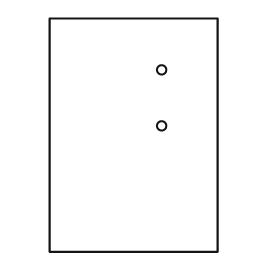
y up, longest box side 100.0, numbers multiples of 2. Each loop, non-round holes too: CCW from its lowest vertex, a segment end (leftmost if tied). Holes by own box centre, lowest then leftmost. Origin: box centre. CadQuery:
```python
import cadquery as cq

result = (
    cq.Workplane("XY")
    .moveTo(-36.0, -50.0)
    .lineTo(36.0, -50.0)
    .lineTo(36.0, 50.0)
    .lineTo(-36.0, 50.0)
    .close()
    .moveTo(12.0, 4.0)
    .circle(2.0)
    .moveTo(12.0, 28.0)
    .circle(2.0)
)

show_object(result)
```